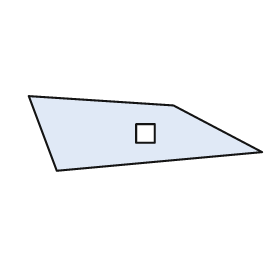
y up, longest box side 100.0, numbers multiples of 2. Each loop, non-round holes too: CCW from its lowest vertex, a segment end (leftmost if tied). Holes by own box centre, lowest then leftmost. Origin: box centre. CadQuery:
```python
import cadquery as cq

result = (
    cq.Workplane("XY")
    .moveTo(-38.0, -16.0)
    .lineTo(50.0, -8.0)
    .lineTo(12.0, 12.0)
    .lineTo(-50.0, 16.0)
    .close()
    .moveTo(-4.0, -4.0)
    .lineTo(4.0, -4.0)
    .lineTo(4.0, 4.0)
    .lineTo(-4.0, 4.0)
    .close()
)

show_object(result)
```